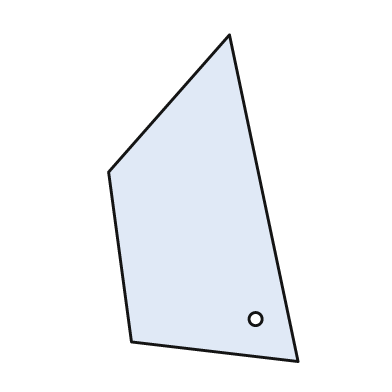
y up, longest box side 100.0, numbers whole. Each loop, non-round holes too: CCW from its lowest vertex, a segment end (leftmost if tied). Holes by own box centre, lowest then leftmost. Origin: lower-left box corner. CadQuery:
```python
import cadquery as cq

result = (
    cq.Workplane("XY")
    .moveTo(58.0, 0.0)
    .lineTo(37.0, 100.0)
    .lineTo(0.0, 58.0)
    .lineTo(7.0, 6.0)
    .close()
    .moveTo(45.0, 13.0)
    .circle(2.0)
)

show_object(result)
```